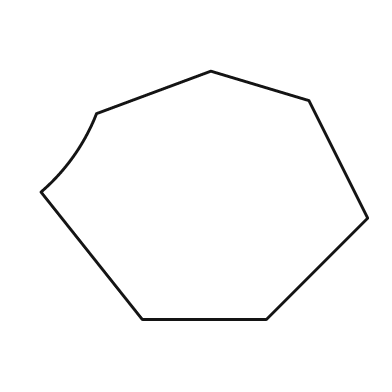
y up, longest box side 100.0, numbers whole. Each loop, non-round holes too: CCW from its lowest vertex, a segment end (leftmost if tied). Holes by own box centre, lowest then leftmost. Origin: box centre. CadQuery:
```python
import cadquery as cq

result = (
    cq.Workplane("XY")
    .moveTo(-19.0, -38.0)
    .lineTo(19.0, -38.0)
    .lineTo(50.0, -7.0)
    .lineTo(32.0, 29.0)
    .lineTo(2.0, 38.0)
    .lineTo(-33.0, 25.0)
    .threePointArc((-40.0, 12.0), (-50.0, 1.0))
    .close()
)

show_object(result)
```